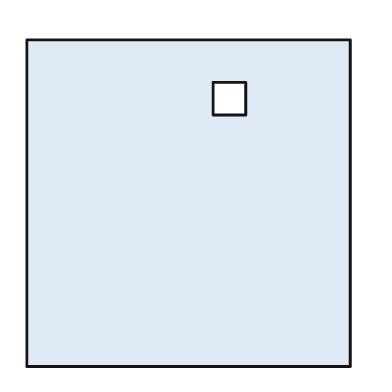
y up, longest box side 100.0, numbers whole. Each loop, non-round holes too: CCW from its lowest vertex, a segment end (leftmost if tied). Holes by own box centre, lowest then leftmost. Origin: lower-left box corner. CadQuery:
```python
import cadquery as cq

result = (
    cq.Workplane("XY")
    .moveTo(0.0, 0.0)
    .lineTo(99.0, 0.0)
    .lineTo(99.0, 100.0)
    .lineTo(0.0, 100.0)
    .close()
    .moveTo(57.0, 77.0)
    .lineTo(67.0, 77.0)
    .lineTo(67.0, 87.0)
    .lineTo(57.0, 87.0)
    .close()
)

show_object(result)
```